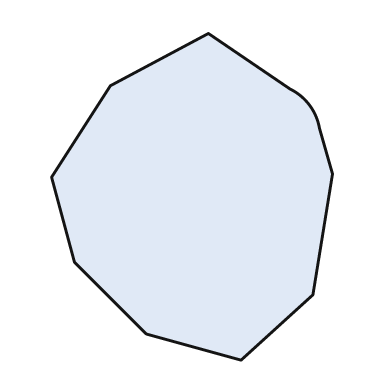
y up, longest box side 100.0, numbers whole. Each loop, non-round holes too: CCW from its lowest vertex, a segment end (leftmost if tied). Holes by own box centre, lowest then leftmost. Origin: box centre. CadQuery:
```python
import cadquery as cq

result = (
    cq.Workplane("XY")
    .moveTo(15.0, -50.0)
    .lineTo(37.0, -30.0)
    .lineTo(43.0, 7.0)
    .lineTo(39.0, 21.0)
    .threePointArc((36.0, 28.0), (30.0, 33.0))
    .lineTo(5.0, 50.0)
    .lineTo(-25.0, 34.0)
    .lineTo(-43.0, 6.0)
    .lineTo(-36.0, -20.0)
    .lineTo(-14.0, -42.0)
    .close()
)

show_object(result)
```